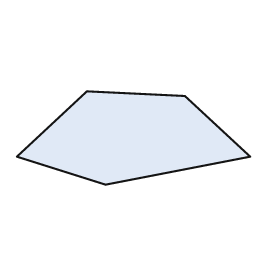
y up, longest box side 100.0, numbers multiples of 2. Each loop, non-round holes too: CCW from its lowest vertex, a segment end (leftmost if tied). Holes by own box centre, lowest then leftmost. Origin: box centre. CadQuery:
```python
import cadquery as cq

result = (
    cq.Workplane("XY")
    .moveTo(-12.0, -20.0)
    .lineTo(50.0, -8.0)
    .lineTo(22.0, 18.0)
    .lineTo(-20.0, 20.0)
    .lineTo(-50.0, -8.0)
    .close()
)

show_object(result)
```